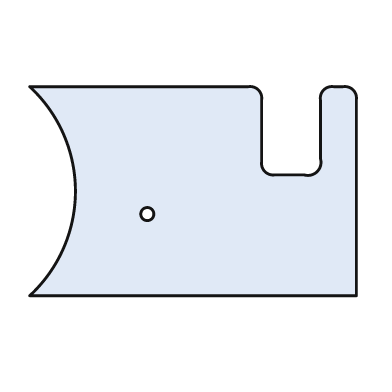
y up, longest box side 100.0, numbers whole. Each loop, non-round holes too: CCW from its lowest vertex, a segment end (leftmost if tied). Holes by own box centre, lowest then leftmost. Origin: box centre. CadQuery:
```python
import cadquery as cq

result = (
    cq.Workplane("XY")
    .moveTo(-50.0, -32.0)
    .lineTo(50.0, -32.0)
    .lineTo(50.0, 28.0)
    .threePointArc((49.0, 31.0), (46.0, 32.0))
    .lineTo(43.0, 32.0)
    .threePointArc((40.0, 31.0), (39.0, 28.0))
    .lineTo(39.0, 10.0)
    .threePointArc((38.0, 6.0), (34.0, 5.0))
    .lineTo(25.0, 5.0)
    .threePointArc((22.0, 6.0), (21.0, 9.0))
    .lineTo(21.0, 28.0)
    .threePointArc((20.0, 31.0), (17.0, 32.0))
    .lineTo(-50.0, 32.0)
    .threePointArc((-36.0, 0.0), (-50.0, -32.0))
    .close()
    .moveTo(-14.0, -7.0)
    .circle(2.0)
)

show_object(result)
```